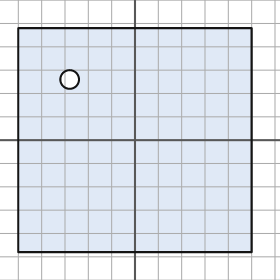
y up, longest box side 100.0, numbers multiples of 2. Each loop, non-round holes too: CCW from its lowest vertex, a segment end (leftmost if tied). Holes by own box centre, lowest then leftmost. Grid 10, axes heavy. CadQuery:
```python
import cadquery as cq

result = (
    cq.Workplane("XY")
    .moveTo(-50.0, -48.0)
    .lineTo(50.0, -48.0)
    .lineTo(50.0, 48.0)
    .lineTo(-50.0, 48.0)
    .close()
    .moveTo(-28.0, 26.0)
    .circle(4.0)
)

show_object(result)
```